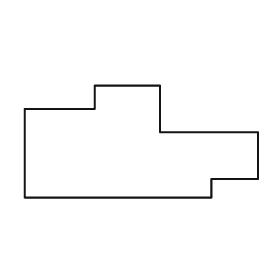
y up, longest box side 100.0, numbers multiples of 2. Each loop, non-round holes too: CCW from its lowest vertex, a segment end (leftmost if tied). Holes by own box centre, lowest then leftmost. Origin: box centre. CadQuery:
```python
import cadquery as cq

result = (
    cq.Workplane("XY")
    .moveTo(-50.0, -24.0)
    .lineTo(30.0, -24.0)
    .lineTo(30.0, -16.0)
    .lineTo(50.0, -16.0)
    .lineTo(50.0, 4.0)
    .lineTo(8.0, 4.0)
    .lineTo(8.0, 24.0)
    .lineTo(-20.0, 24.0)
    .lineTo(-20.0, 14.0)
    .lineTo(-50.0, 14.0)
    .close()
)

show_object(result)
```